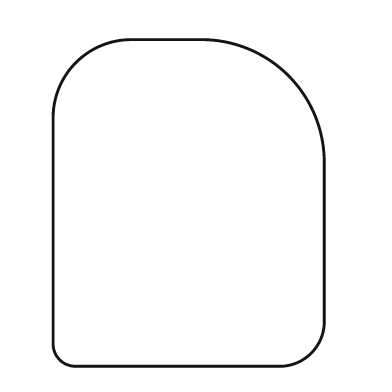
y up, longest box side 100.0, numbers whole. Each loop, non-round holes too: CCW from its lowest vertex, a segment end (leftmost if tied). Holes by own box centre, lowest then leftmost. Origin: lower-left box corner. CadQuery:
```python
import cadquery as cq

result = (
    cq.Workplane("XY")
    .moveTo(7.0, 0.0)
    .lineTo(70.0, 0.0)
    .threePointArc((79.0, 4.0), (83.0, 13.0))
    .lineTo(83.0, 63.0)
    .threePointArc((72.0, 89.0), (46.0, 100.0))
    .lineTo(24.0, 100.0)
    .threePointArc((7.0, 93.0), (0.0, 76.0))
    .lineTo(0.0, 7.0)
    .threePointArc((2.0, 2.0), (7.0, 0.0))
    .close()
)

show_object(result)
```